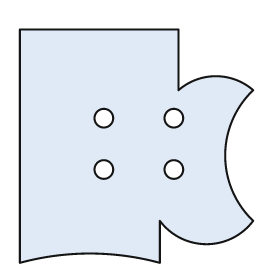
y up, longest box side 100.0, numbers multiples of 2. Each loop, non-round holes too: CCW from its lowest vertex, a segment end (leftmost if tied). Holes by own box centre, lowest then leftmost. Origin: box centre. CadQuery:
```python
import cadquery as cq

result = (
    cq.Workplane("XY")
    .moveTo(-50.0, -50.0)
    .threePointArc((-20.0, -46.0), (10.0, -50.0))
    .lineTo(10.0, -32.0)
    .threePointArc((30.0, -42.0), (50.0, -32.0))
    .threePointArc((38.0, -4.0), (50.0, 24.0))
    .threePointArc((34.0, 30.0), (18.0, 24.0))
    .lineTo(18.0, 50.0)
    .lineTo(-50.0, 50.0)
    .close()
    .moveTo(-14.0, -10.0)
    .circle(4.0)
    .moveTo(16.0, -10.0)
    .circle(4.0)
    .moveTo(-14.0, 12.0)
    .circle(4.0)
    .moveTo(16.0, 12.0)
    .circle(4.0)
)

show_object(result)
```